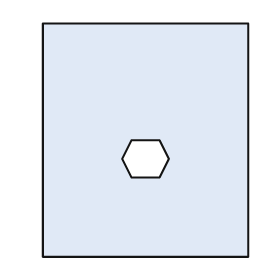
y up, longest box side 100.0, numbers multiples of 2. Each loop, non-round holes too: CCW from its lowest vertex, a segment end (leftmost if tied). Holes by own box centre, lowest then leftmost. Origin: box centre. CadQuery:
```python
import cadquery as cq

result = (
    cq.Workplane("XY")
    .moveTo(-44.0, -50.0)
    .lineTo(44.0, -50.0)
    .lineTo(44.0, 50.0)
    .lineTo(-44.0, 50.0)
    .close()
    .moveTo(-6.0, -16.0)
    .lineTo(6.0, -16.0)
    .lineTo(10.0, -8.0)
    .lineTo(6.0, 0.0)
    .lineTo(-6.0, 0.0)
    .lineTo(-10.0, -8.0)
    .close()
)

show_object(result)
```